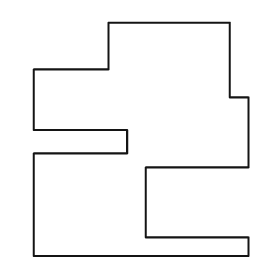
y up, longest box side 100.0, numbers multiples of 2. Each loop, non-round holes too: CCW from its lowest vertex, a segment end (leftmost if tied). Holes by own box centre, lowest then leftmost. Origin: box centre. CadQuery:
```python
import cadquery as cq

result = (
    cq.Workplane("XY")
    .moveTo(-46.0, -50.0)
    .lineTo(46.0, -50.0)
    .lineTo(46.0, -42.0)
    .lineTo(2.0, -42.0)
    .lineTo(2.0, -12.0)
    .lineTo(46.0, -12.0)
    .lineTo(46.0, 18.0)
    .lineTo(38.0, 18.0)
    .lineTo(38.0, 50.0)
    .lineTo(-14.0, 50.0)
    .lineTo(-14.0, 30.0)
    .lineTo(-46.0, 30.0)
    .lineTo(-46.0, 4.0)
    .lineTo(-6.0, 4.0)
    .lineTo(-6.0, -6.0)
    .lineTo(-46.0, -6.0)
    .close()
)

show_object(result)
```